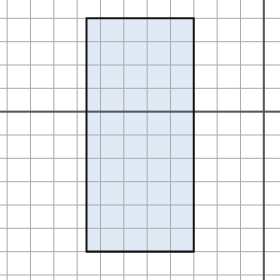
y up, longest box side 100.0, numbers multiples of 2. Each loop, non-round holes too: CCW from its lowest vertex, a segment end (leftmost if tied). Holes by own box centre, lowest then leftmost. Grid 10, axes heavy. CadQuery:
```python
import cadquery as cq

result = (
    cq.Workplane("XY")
    .moveTo(-76.0, -60.0)
    .lineTo(-30.0, -60.0)
    .lineTo(-30.0, 40.0)
    .lineTo(-76.0, 40.0)
    .close()
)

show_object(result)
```